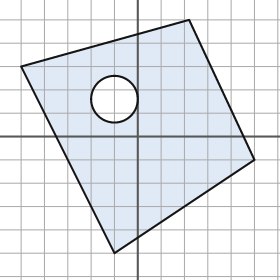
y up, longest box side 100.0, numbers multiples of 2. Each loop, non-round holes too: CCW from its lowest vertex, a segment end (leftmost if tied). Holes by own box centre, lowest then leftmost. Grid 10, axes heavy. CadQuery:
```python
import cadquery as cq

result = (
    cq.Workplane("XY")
    .moveTo(-10.0, -50.0)
    .lineTo(50.0, -10.0)
    .lineTo(22.0, 50.0)
    .lineTo(-50.0, 30.0)
    .close()
    .moveTo(-10.0, 16.0)
    .circle(10.0)
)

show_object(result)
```